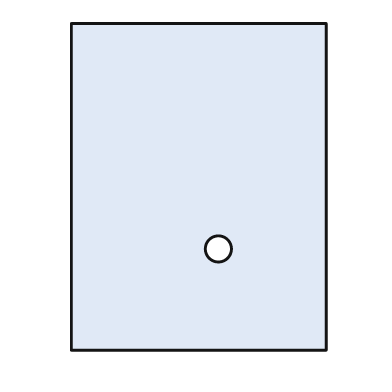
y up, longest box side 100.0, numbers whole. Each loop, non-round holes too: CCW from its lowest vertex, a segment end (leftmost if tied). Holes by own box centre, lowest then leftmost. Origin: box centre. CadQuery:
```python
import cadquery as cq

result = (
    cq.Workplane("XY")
    .moveTo(-39.0, -50.0)
    .lineTo(39.0, -50.0)
    .lineTo(39.0, 50.0)
    .lineTo(-39.0, 50.0)
    .close()
    .moveTo(6.0, -19.0)
    .circle(4.0)
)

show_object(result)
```